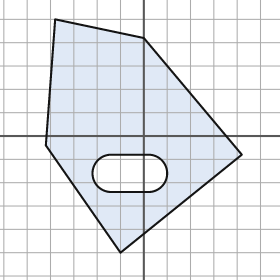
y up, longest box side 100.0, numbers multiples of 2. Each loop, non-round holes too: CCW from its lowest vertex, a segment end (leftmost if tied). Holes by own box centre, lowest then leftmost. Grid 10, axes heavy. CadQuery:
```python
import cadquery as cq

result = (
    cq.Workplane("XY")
    .moveTo(-10.0, -50.0)
    .lineTo(42.0, -8.0)
    .lineTo(0.0, 42.0)
    .lineTo(-38.0, 50.0)
    .lineTo(-42.0, -4.0)
    .close()
    .moveTo(-14.0, -24.0)
    .lineTo(2.0, -24.0)
    .threePointArc((10.0, -16.0), (2.0, -8.0))
    .lineTo(-14.0, -8.0)
    .threePointArc((-22.0, -16.0), (-14.0, -24.0))
    .close()
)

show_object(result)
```